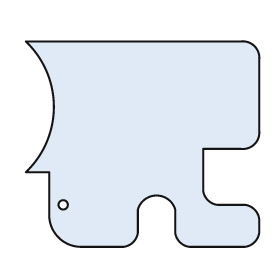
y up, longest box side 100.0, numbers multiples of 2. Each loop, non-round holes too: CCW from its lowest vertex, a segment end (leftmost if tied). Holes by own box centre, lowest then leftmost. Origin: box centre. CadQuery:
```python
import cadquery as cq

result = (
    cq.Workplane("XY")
    .moveTo(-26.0, -44.0)
    .lineTo(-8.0, -44.0)
    .threePointArc((-4.0, -42.0), (-2.0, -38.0))
    .lineTo(-2.0, -28.0)
    .threePointArc((6.0, -22.0), (14.0, -28.0))
    .lineTo(14.0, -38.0)
    .threePointArc((16.0, -42.0), (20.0, -44.0))
    .lineTo(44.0, -44.0)
    .threePointArc((48.0, -42.0), (50.0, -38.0))
    .lineTo(50.0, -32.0)
    .threePointArc((48.0, -28.0), (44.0, -26.0))
    .lineTo(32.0, -26.0)
    .threePointArc((28.0, -24.0), (26.0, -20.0))
    .lineTo(26.0, -2.0)
    .lineTo(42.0, -2.0)
    .threePointArc((48.0, 0.0), (50.0, 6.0))
    .lineTo(50.0, 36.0)
    .threePointArc((48.0, 42.0), (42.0, 44.0))
    .lineTo(-50.0, 44.0)
    .threePointArc((-38.0, 16.0), (-50.0, -12.0))
    .lineTo(-40.0, -12.0)
    .lineTo(-40.0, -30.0)
    .threePointArc((-36.0, -40.0), (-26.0, -44.0))
    .close()
    .moveTo(-34.0, -26.0)
    .circle(2.0)
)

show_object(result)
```